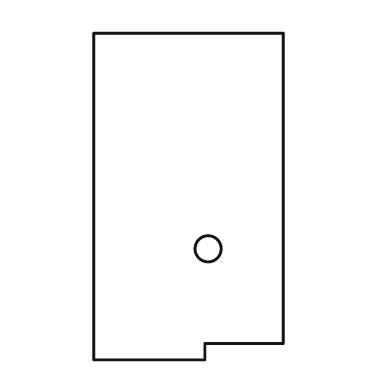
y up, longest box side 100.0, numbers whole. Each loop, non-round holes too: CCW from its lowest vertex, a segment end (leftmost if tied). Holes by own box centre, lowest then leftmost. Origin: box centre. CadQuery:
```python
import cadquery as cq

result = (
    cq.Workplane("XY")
    .moveTo(-29.0, -50.0)
    .lineTo(5.0, -50.0)
    .lineTo(5.0, -45.0)
    .lineTo(29.0, -45.0)
    .lineTo(29.0, 50.0)
    .lineTo(-29.0, 50.0)
    .close()
    .moveTo(6.0, -16.0)
    .circle(4.0)
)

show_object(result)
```